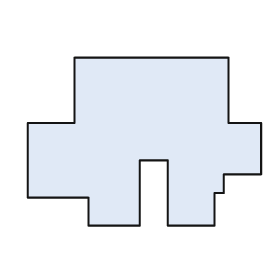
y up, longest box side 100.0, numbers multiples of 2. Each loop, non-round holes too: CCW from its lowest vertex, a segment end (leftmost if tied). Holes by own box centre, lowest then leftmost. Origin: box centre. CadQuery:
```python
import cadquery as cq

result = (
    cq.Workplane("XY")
    .moveTo(-24.0, -36.0)
    .lineTo(-2.0, -36.0)
    .lineTo(-2.0, -8.0)
    .lineTo(10.0, -8.0)
    .lineTo(10.0, -36.0)
    .lineTo(30.0, -36.0)
    .lineTo(30.0, -22.0)
    .lineTo(34.0, -22.0)
    .lineTo(34.0, -14.0)
    .lineTo(50.0, -14.0)
    .lineTo(50.0, 8.0)
    .lineTo(36.0, 8.0)
    .lineTo(36.0, 36.0)
    .lineTo(-30.0, 36.0)
    .lineTo(-30.0, 8.0)
    .lineTo(-50.0, 8.0)
    .lineTo(-50.0, -24.0)
    .lineTo(-24.0, -24.0)
    .close()
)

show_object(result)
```